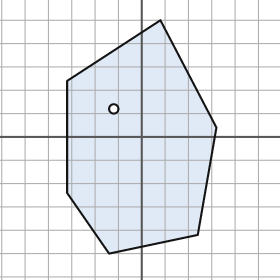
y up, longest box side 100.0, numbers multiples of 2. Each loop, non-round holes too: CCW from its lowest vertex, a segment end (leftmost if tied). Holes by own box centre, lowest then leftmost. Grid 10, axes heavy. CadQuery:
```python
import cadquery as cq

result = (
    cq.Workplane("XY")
    .moveTo(-14.0, -50.0)
    .lineTo(24.0, -42.0)
    .lineTo(32.0, 4.0)
    .lineTo(8.0, 50.0)
    .lineTo(-32.0, 24.0)
    .lineTo(-32.0, -24.0)
    .close()
    .moveTo(-12.0, 12.0)
    .circle(2.0)
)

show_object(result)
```